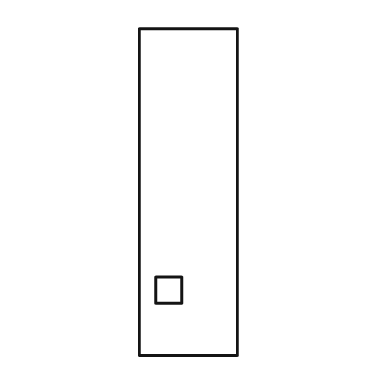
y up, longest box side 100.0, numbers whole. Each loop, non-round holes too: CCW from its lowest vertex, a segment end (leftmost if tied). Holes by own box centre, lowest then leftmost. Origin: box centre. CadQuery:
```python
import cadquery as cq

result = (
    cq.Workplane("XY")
    .moveTo(-15.0, -50.0)
    .lineTo(15.0, -50.0)
    .lineTo(15.0, 50.0)
    .lineTo(-15.0, 50.0)
    .close()
    .moveTo(-10.0, -34.0)
    .lineTo(-2.0, -34.0)
    .lineTo(-2.0, -26.0)
    .lineTo(-10.0, -26.0)
    .close()
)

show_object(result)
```